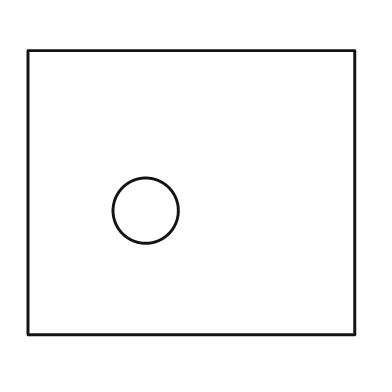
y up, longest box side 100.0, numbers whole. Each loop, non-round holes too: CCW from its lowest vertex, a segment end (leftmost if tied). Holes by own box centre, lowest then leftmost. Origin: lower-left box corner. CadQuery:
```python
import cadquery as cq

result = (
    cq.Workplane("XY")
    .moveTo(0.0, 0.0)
    .lineTo(100.0, 0.0)
    .lineTo(100.0, 87.0)
    .lineTo(0.0, 87.0)
    .close()
    .moveTo(36.0, 38.0)
    .circle(10.0)
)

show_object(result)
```